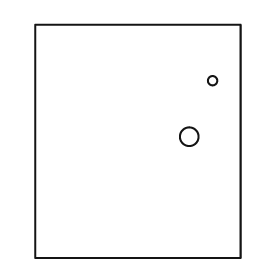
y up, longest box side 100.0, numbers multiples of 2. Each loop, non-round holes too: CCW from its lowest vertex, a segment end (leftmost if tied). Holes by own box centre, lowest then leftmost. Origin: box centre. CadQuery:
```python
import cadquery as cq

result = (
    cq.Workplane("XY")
    .moveTo(-44.0, -50.0)
    .lineTo(44.0, -50.0)
    .lineTo(44.0, 50.0)
    .lineTo(-44.0, 50.0)
    .close()
    .moveTo(22.0, 2.0)
    .circle(4.0)
    .moveTo(32.0, 26.0)
    .circle(2.0)
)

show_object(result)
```